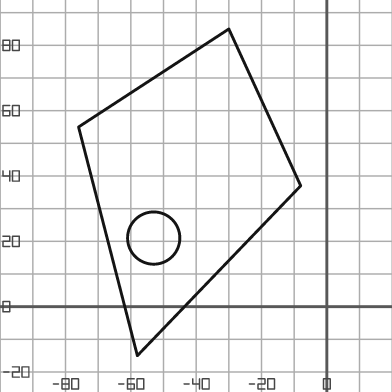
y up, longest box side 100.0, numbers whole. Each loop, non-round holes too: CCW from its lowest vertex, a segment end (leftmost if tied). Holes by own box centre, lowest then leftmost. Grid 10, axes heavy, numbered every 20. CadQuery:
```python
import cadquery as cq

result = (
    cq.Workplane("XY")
    .moveTo(-58.0, -15.0)
    .lineTo(-8.0, 37.0)
    .lineTo(-30.0, 85.0)
    .lineTo(-76.0, 55.0)
    .close()
    .moveTo(-53.0, 21.0)
    .circle(8.0)
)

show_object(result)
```